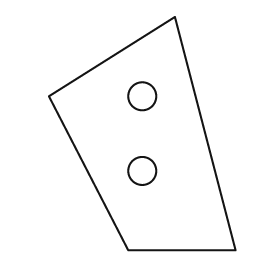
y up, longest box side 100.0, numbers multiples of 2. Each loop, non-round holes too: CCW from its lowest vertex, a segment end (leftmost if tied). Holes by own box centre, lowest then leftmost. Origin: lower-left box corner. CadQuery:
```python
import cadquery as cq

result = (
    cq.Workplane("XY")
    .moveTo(34.0, 0.0)
    .lineTo(80.0, 0.0)
    .lineTo(54.0, 100.0)
    .lineTo(0.0, 66.0)
    .close()
    .moveTo(40.0, 34.0)
    .circle(6.0)
    .moveTo(40.0, 66.0)
    .circle(6.0)
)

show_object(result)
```